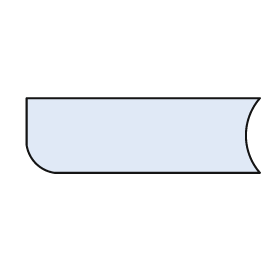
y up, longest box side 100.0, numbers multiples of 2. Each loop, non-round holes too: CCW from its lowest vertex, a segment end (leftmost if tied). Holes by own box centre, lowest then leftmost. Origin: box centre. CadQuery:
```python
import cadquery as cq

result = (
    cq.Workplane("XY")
    .moveTo(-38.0, -16.0)
    .lineTo(50.0, -16.0)
    .threePointArc((44.0, 0.0), (50.0, 16.0))
    .lineTo(-50.0, 16.0)
    .lineTo(-50.0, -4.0)
    .threePointArc((-46.0, -12.0), (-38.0, -16.0))
    .close()
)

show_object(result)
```